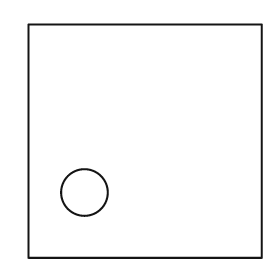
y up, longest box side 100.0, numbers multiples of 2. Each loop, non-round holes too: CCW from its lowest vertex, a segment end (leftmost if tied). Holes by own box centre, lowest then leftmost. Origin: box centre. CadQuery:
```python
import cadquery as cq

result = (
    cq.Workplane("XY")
    .moveTo(-50.0, -50.0)
    .lineTo(50.0, -50.0)
    .lineTo(50.0, 50.0)
    .lineTo(-50.0, 50.0)
    .close()
    .moveTo(-26.0, -22.0)
    .circle(10.0)
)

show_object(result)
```